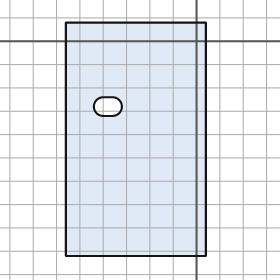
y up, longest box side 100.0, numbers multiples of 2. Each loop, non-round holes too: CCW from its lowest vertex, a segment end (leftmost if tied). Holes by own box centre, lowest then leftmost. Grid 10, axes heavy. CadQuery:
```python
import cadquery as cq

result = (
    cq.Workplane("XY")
    .moveTo(-56.0, -92.0)
    .lineTo(4.0, -92.0)
    .lineTo(4.0, 8.0)
    .lineTo(-56.0, 8.0)
    .close()
    .moveTo(-40.0, -32.0)
    .lineTo(-36.0, -32.0)
    .threePointArc((-32.0, -28.0), (-36.0, -24.0))
    .lineTo(-40.0, -24.0)
    .threePointArc((-44.0, -28.0), (-40.0, -32.0))
    .close()
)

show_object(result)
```